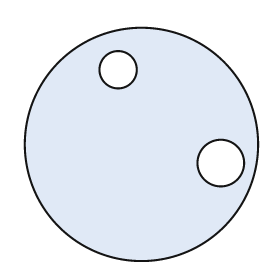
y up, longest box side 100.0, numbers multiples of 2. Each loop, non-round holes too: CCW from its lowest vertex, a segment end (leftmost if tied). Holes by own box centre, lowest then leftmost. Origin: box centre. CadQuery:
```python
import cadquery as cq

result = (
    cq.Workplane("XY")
    .moveTo(0.0, 0.0)
    .circle(50.0)
    .moveTo(34.0, -8.0)
    .circle(10.0)
    .moveTo(-10.0, 32.0)
    .circle(8.0)
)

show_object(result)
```